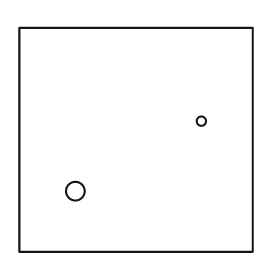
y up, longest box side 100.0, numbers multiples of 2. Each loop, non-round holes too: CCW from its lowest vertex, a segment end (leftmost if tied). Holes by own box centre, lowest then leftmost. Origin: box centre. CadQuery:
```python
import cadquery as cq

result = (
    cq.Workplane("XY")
    .moveTo(-50.0, -48.0)
    .lineTo(50.0, -48.0)
    .lineTo(50.0, 48.0)
    .lineTo(-50.0, 48.0)
    .close()
    .moveTo(-26.0, -22.0)
    .circle(4.0)
    .moveTo(28.0, 8.0)
    .circle(2.0)
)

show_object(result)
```